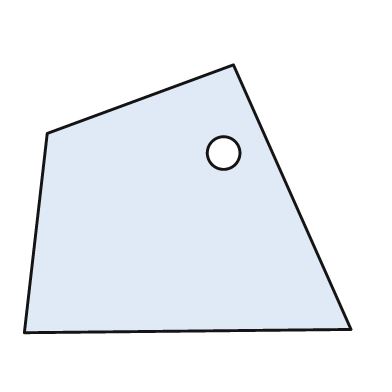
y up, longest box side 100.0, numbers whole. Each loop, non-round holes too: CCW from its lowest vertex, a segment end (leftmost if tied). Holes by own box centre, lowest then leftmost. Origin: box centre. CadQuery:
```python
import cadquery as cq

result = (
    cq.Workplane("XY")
    .moveTo(-50.0, -41.0)
    .lineTo(50.0, -40.0)
    .lineTo(14.0, 41.0)
    .lineTo(-43.0, 20.0)
    .close()
    .moveTo(11.0, 14.0)
    .circle(5.0)
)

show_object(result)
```